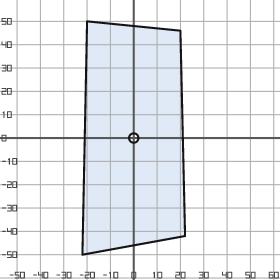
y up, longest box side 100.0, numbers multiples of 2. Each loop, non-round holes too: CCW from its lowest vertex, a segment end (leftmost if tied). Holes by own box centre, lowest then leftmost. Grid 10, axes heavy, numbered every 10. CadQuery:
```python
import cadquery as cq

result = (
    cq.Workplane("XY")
    .moveTo(-22.0, -50.0)
    .lineTo(22.0, -42.0)
    .lineTo(20.0, 46.0)
    .lineTo(-20.0, 50.0)
    .close()
    .moveTo(0.0, 0.0)
    .circle(2.0)
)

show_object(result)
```